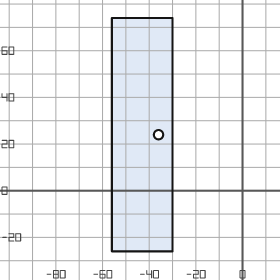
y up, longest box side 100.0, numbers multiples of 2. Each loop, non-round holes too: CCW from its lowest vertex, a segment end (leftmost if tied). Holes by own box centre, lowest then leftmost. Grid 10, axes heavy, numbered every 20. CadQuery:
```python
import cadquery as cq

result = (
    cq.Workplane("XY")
    .moveTo(-56.0, -26.0)
    .lineTo(-30.0, -26.0)
    .lineTo(-30.0, 74.0)
    .lineTo(-56.0, 74.0)
    .close()
    .moveTo(-36.0, 24.0)
    .circle(2.0)
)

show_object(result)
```